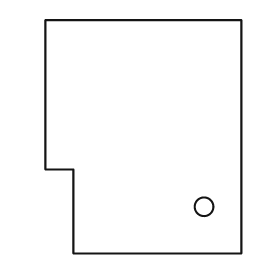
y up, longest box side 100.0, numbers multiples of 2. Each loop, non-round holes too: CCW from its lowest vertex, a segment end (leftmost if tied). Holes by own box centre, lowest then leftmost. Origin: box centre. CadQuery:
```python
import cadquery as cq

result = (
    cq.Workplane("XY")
    .moveTo(-30.0, -50.0)
    .lineTo(42.0, -50.0)
    .lineTo(42.0, 50.0)
    .lineTo(-42.0, 50.0)
    .lineTo(-42.0, -14.0)
    .lineTo(-30.0, -14.0)
    .close()
    .moveTo(26.0, -30.0)
    .circle(4.0)
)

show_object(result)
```